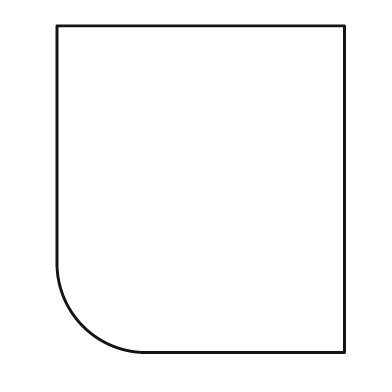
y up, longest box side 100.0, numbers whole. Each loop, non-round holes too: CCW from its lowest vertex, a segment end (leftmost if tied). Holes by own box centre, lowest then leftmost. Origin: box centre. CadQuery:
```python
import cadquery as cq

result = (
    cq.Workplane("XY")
    .moveTo(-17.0, -50.0)
    .lineTo(44.0, -50.0)
    .lineTo(44.0, 50.0)
    .lineTo(-44.0, 50.0)
    .lineTo(-44.0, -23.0)
    .threePointArc((-36.0, -42.0), (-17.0, -50.0))
    .close()
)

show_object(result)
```